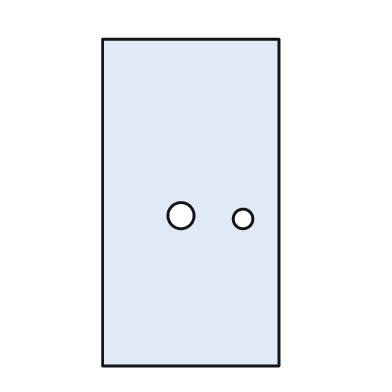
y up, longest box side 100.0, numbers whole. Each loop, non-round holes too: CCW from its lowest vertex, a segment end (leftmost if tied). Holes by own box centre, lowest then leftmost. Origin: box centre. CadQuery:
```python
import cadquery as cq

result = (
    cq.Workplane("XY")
    .moveTo(-27.0, -50.0)
    .lineTo(27.0, -50.0)
    .lineTo(27.0, 50.0)
    .lineTo(-27.0, 50.0)
    .close()
    .moveTo(16.0, -5.0)
    .circle(3.0)
    .moveTo(-3.0, -4.0)
    .circle(4.0)
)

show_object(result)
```